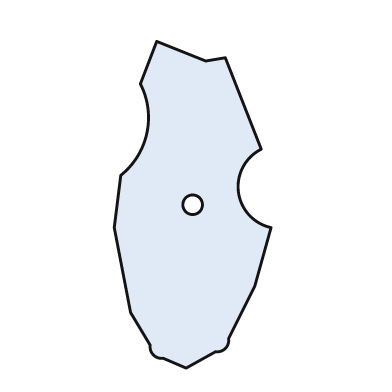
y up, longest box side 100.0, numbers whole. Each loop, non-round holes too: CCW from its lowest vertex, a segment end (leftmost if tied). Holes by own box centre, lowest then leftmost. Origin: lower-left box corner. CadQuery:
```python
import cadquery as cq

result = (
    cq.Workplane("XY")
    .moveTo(22.0, 0.0)
    .lineTo(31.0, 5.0)
    .threePointArc((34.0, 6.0), (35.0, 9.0))
    .lineTo(43.0, 25.0)
    .lineTo(48.0, 43.0)
    .threePointArc((38.0, 54.0), (45.0, 67.0))
    .lineTo(34.0, 95.0)
    .lineTo(28.0, 94.0)
    .lineTo(13.0, 100.0)
    .lineTo(8.0, 87.0)
    .threePointArc((10.0, 72.0), (2.0, 59.0))
    .lineTo(0.0, 43.0)
    .lineTo(5.0, 17.0)
    .lineTo(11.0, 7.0)
    .threePointArc((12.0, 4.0), (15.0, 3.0))
    .close()
    .moveTo(24.0, 50.0)
    .circle(3.0)
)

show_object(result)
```